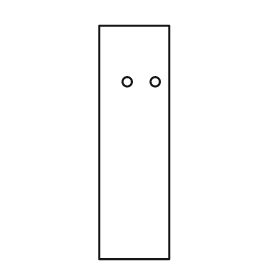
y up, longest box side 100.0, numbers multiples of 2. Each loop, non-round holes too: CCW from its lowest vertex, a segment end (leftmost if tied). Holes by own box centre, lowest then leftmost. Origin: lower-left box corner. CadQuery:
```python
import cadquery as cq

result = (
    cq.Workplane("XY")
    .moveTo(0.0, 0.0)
    .lineTo(30.0, 0.0)
    .lineTo(30.0, 100.0)
    .lineTo(0.0, 100.0)
    .close()
    .moveTo(12.0, 76.0)
    .circle(2.0)
    .moveTo(24.0, 76.0)
    .circle(2.0)
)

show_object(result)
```